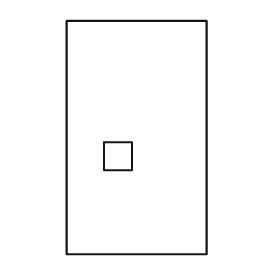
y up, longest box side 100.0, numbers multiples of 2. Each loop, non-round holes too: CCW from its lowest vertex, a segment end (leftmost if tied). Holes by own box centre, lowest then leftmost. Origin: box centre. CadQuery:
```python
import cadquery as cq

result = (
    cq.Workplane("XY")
    .moveTo(-30.0, -50.0)
    .lineTo(30.0, -50.0)
    .lineTo(30.0, 50.0)
    .lineTo(-30.0, 50.0)
    .close()
    .moveTo(-14.0, -14.0)
    .lineTo(-2.0, -14.0)
    .lineTo(-2.0, -2.0)
    .lineTo(-14.0, -2.0)
    .close()
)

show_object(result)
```